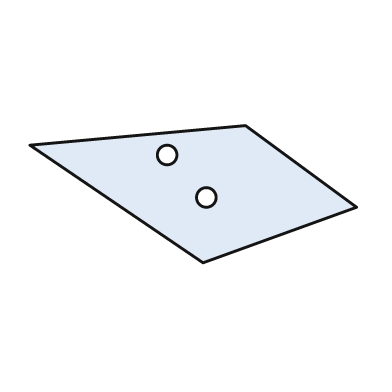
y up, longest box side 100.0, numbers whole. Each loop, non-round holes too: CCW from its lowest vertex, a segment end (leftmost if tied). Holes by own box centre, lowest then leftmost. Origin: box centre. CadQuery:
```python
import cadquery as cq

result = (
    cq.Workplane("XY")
    .moveTo(3.0, -21.0)
    .lineTo(50.0, -4.0)
    .lineTo(16.0, 21.0)
    .lineTo(-50.0, 15.0)
    .close()
    .moveTo(4.0, -1.0)
    .circle(3.0)
    .moveTo(-8.0, 12.0)
    .circle(3.0)
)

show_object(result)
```